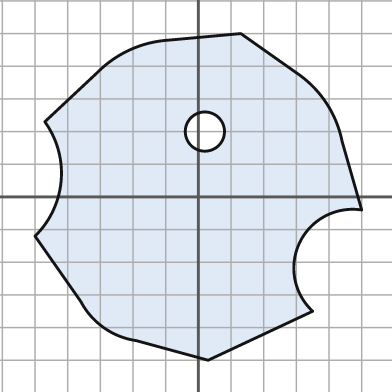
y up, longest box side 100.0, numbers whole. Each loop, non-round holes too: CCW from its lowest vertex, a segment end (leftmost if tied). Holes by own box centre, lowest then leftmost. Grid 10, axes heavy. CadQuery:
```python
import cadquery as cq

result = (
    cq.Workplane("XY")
    .moveTo(3.0, -50.0)
    .lineTo(35.0, -35.0)
    .threePointArc((31.0, -14.0), (50.0, -4.0))
    .lineTo(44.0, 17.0)
    .threePointArc((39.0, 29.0), (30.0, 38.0))
    .lineTo(13.0, 50.0)
    .lineTo(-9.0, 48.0)
    .threePointArc((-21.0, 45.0), (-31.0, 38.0))
    .lineTo(-47.0, 23.0)
    .threePointArc((-42.0, 5.0), (-50.0, -12.0))
    .lineTo(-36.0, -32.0)
    .threePointArc((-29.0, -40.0), (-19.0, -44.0))
    .close()
    .moveTo(2.0, 20.0)
    .circle(6.0)
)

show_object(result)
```